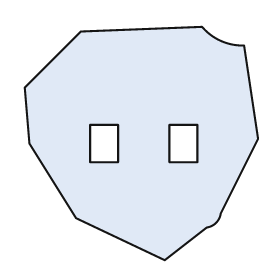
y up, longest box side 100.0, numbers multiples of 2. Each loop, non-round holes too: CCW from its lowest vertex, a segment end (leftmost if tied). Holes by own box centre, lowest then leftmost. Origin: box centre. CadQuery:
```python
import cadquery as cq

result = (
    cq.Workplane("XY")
    .moveTo(10.0, -50.0)
    .lineTo(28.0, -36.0)
    .threePointArc((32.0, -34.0), (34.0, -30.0))
    .lineTo(50.0, 2.0)
    .lineTo(44.0, 42.0)
    .threePointArc((34.0, 44.0), (26.0, 50.0))
    .lineTo(-26.0, 48.0)
    .lineTo(-50.0, 24.0)
    .lineTo(-48.0, 0.0)
    .lineTo(-28.0, -32.0)
    .close()
    .moveTo(-22.0, -8.0)
    .lineTo(-10.0, -8.0)
    .lineTo(-10.0, 8.0)
    .lineTo(-22.0, 8.0)
    .close()
    .moveTo(12.0, -8.0)
    .lineTo(24.0, -8.0)
    .lineTo(24.0, 8.0)
    .lineTo(12.0, 8.0)
    .close()
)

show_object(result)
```